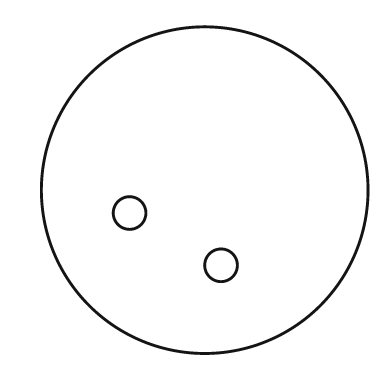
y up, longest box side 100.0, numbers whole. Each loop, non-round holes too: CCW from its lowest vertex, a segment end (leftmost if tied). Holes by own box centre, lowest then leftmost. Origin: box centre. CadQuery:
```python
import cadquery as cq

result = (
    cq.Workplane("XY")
    .moveTo(0.0, 0.0)
    .circle(50.0)
    .moveTo(5.0, -23.0)
    .circle(5.0)
    .moveTo(-23.0, -7.0)
    .circle(5.0)
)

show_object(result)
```